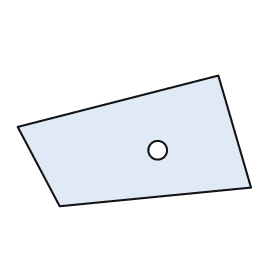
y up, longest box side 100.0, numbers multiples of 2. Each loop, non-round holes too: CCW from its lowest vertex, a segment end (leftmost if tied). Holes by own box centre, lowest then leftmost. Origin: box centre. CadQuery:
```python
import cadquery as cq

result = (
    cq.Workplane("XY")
    .moveTo(-32.0, -28.0)
    .lineTo(50.0, -20.0)
    .lineTo(36.0, 28.0)
    .lineTo(-50.0, 6.0)
    .close()
    .moveTo(10.0, -4.0)
    .circle(4.0)
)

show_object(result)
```